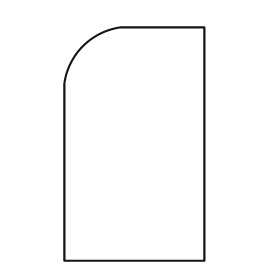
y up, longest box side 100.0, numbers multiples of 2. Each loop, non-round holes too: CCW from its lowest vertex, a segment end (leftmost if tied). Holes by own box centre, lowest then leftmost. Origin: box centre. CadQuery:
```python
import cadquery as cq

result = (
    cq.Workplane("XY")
    .moveTo(-30.0, -50.0)
    .lineTo(30.0, -50.0)
    .lineTo(30.0, 50.0)
    .lineTo(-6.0, 50.0)
    .threePointArc((-22.0, 42.0), (-30.0, 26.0))
    .close()
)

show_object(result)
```